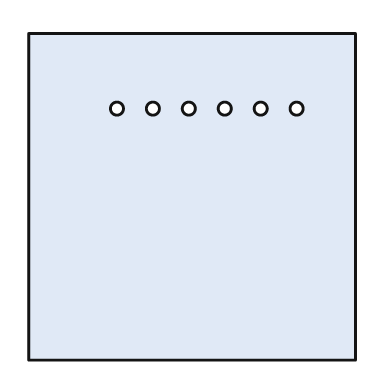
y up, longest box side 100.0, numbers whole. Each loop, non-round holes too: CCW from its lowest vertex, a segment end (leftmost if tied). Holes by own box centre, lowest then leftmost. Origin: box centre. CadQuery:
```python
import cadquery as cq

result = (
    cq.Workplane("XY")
    .moveTo(-50.0, -50.0)
    .lineTo(50.0, -50.0)
    .lineTo(50.0, 50.0)
    .lineTo(-50.0, 50.0)
    .close()
    .moveTo(-23.0, 27.0)
    .circle(2.0)
    .moveTo(-12.0, 27.0)
    .circle(2.0)
    .moveTo(-1.0, 27.0)
    .circle(2.0)
    .moveTo(10.0, 27.0)
    .circle(2.0)
    .moveTo(21.0, 27.0)
    .circle(2.0)
    .moveTo(32.0, 27.0)
    .circle(2.0)
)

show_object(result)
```